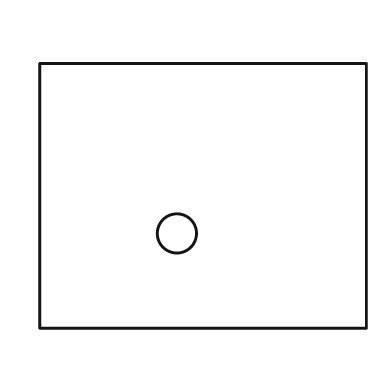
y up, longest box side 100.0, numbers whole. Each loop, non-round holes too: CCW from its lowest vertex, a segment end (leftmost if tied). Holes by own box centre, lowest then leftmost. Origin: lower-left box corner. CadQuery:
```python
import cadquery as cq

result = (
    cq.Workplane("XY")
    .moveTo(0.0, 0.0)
    .lineTo(100.0, 0.0)
    .lineTo(100.0, 81.0)
    .lineTo(0.0, 81.0)
    .close()
    .moveTo(42.0, 29.0)
    .circle(6.0)
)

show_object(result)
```